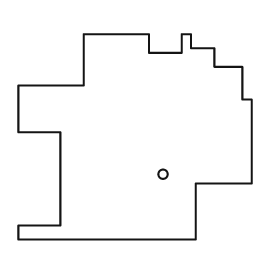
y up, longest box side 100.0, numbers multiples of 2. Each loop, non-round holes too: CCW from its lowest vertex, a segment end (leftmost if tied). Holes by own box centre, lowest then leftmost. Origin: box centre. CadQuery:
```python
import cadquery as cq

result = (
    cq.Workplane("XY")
    .moveTo(-50.0, -44.0)
    .lineTo(26.0, -44.0)
    .lineTo(26.0, -20.0)
    .lineTo(50.0, -20.0)
    .lineTo(50.0, 16.0)
    .lineTo(46.0, 16.0)
    .lineTo(46.0, 30.0)
    .lineTo(34.0, 30.0)
    .lineTo(34.0, 38.0)
    .lineTo(24.0, 38.0)
    .lineTo(24.0, 44.0)
    .lineTo(20.0, 44.0)
    .lineTo(20.0, 36.0)
    .lineTo(6.0, 36.0)
    .lineTo(6.0, 44.0)
    .lineTo(-22.0, 44.0)
    .lineTo(-22.0, 22.0)
    .lineTo(-50.0, 22.0)
    .lineTo(-50.0, 2.0)
    .lineTo(-32.0, 2.0)
    .lineTo(-32.0, -38.0)
    .lineTo(-50.0, -38.0)
    .close()
    .moveTo(12.0, -16.0)
    .circle(2.0)
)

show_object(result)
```